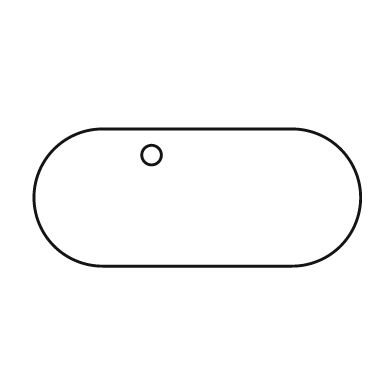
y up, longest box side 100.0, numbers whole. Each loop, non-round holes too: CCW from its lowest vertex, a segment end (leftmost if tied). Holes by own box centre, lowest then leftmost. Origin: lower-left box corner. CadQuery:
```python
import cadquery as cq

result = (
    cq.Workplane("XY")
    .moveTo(21.0, 0.0)
    .lineTo(79.0, 0.0)
    .threePointArc((100.0, 21.0), (79.0, 42.0))
    .lineTo(21.0, 42.0)
    .threePointArc((0.0, 21.0), (21.0, 0.0))
    .close()
    .moveTo(36.0, 34.0)
    .circle(3.0)
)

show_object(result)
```